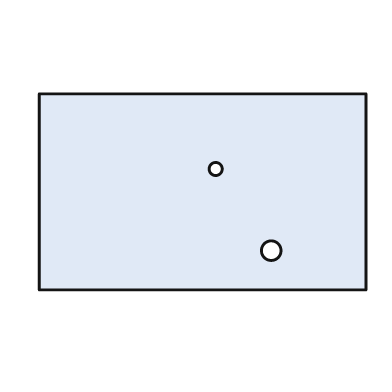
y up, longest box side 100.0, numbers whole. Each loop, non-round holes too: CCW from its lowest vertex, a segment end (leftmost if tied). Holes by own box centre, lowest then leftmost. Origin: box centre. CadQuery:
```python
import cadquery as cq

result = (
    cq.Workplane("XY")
    .moveTo(-50.0, -30.0)
    .lineTo(50.0, -30.0)
    .lineTo(50.0, 30.0)
    .lineTo(-50.0, 30.0)
    .close()
    .moveTo(21.0, -18.0)
    .circle(3.0)
    .moveTo(4.0, 7.0)
    .circle(2.0)
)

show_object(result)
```